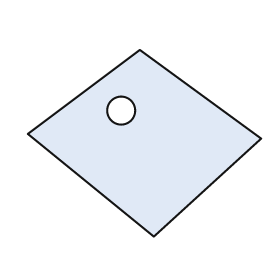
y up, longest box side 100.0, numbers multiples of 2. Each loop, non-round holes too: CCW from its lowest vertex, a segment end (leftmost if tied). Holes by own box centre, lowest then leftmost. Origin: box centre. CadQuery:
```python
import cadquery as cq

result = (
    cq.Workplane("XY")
    .moveTo(4.0, -40.0)
    .lineTo(50.0, 2.0)
    .lineTo(-2.0, 40.0)
    .lineTo(-50.0, 4.0)
    .close()
    .moveTo(-10.0, 14.0)
    .circle(6.0)
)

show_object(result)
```